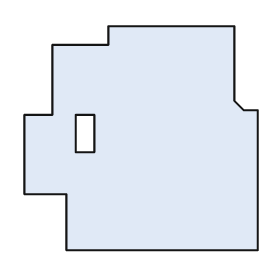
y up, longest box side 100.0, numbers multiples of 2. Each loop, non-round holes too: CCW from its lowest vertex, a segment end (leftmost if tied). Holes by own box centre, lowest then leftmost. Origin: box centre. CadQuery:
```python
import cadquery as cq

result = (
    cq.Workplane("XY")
    .moveTo(-32.0, -48.0)
    .lineTo(50.0, -48.0)
    .lineTo(50.0, 12.0)
    .lineTo(44.0, 12.0)
    .lineTo(40.0, 16.0)
    .lineTo(40.0, 48.0)
    .lineTo(-14.0, 48.0)
    .lineTo(-14.0, 40.0)
    .lineTo(-38.0, 40.0)
    .lineTo(-38.0, 10.0)
    .lineTo(-50.0, 10.0)
    .lineTo(-50.0, -24.0)
    .lineTo(-32.0, -24.0)
    .close()
    .moveTo(-28.0, -6.0)
    .lineTo(-20.0, -6.0)
    .lineTo(-20.0, 10.0)
    .lineTo(-28.0, 10.0)
    .close()
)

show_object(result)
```